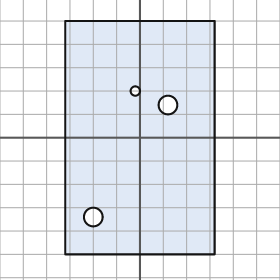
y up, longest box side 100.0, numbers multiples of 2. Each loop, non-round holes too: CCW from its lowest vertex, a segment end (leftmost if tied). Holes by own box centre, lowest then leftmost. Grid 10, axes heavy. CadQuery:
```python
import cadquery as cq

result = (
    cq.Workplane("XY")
    .moveTo(-32.0, -50.0)
    .lineTo(32.0, -50.0)
    .lineTo(32.0, 50.0)
    .lineTo(-32.0, 50.0)
    .close()
    .moveTo(-20.0, -34.0)
    .circle(4.0)
    .moveTo(12.0, 14.0)
    .circle(4.0)
    .moveTo(-2.0, 20.0)
    .circle(2.0)
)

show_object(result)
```